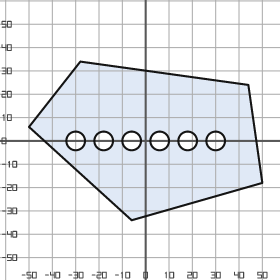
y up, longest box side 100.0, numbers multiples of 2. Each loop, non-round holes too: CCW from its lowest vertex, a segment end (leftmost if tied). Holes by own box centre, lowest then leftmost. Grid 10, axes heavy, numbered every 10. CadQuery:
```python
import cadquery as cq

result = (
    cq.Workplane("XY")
    .moveTo(-6.0, -34.0)
    .lineTo(50.0, -18.0)
    .lineTo(44.0, 24.0)
    .lineTo(-28.0, 34.0)
    .lineTo(-50.0, 6.0)
    .close()
    .moveTo(-30.0, 0.0)
    .circle(4.0)
    .moveTo(-18.0, 0.0)
    .circle(4.0)
    .moveTo(-6.0, 0.0)
    .circle(4.0)
    .moveTo(6.0, 0.0)
    .circle(4.0)
    .moveTo(18.0, 0.0)
    .circle(4.0)
    .moveTo(30.0, 0.0)
    .circle(4.0)
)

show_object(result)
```